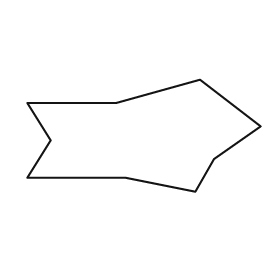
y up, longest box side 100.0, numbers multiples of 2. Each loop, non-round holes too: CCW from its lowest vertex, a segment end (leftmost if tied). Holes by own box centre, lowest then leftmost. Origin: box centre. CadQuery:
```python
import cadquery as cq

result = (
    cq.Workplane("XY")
    .moveTo(22.0, -24.0)
    .lineTo(30.0, -10.0)
    .lineTo(50.0, 4.0)
    .lineTo(24.0, 24.0)
    .lineTo(-12.0, 14.0)
    .lineTo(-50.0, 14.0)
    .lineTo(-40.0, -2.0)
    .lineTo(-50.0, -18.0)
    .lineTo(-8.0, -18.0)
    .close()
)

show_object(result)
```